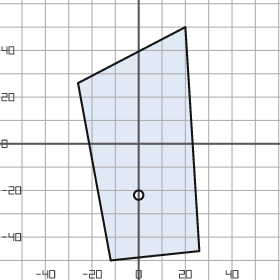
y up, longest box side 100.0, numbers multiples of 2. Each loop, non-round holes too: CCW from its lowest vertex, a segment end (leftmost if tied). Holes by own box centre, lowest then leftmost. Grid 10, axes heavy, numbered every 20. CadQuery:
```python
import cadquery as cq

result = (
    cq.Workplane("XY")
    .moveTo(-12.0, -50.0)
    .lineTo(26.0, -46.0)
    .lineTo(20.0, 50.0)
    .lineTo(-26.0, 26.0)
    .close()
    .moveTo(0.0, -22.0)
    .circle(2.0)
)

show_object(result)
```